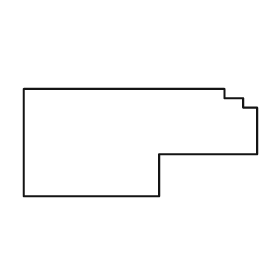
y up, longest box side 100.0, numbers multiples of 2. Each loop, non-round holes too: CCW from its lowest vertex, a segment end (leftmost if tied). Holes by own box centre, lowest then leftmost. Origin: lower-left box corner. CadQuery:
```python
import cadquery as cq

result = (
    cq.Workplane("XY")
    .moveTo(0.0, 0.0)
    .lineTo(58.0, 0.0)
    .lineTo(58.0, 18.0)
    .lineTo(100.0, 18.0)
    .lineTo(100.0, 38.0)
    .lineTo(94.0, 38.0)
    .lineTo(94.0, 42.0)
    .lineTo(86.0, 42.0)
    .lineTo(86.0, 46.0)
    .lineTo(0.0, 46.0)
    .close()
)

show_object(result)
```